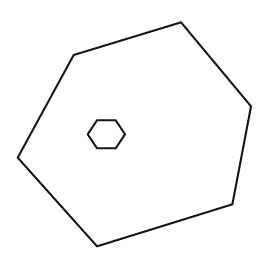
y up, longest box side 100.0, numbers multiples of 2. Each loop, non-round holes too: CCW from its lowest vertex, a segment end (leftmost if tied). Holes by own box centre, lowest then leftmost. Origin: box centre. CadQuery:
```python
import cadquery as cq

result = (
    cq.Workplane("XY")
    .moveTo(-16.0, -48.0)
    .lineTo(42.0, -30.0)
    .lineTo(50.0, 12.0)
    .lineTo(20.0, 48.0)
    .lineTo(-26.0, 34.0)
    .lineTo(-50.0, -10.0)
    .close()
    .moveTo(-16.0, -6.0)
    .lineTo(-8.0, -6.0)
    .lineTo(-4.0, 0.0)
    .lineTo(-8.0, 6.0)
    .lineTo(-16.0, 6.0)
    .lineTo(-20.0, 0.0)
    .close()
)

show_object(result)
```